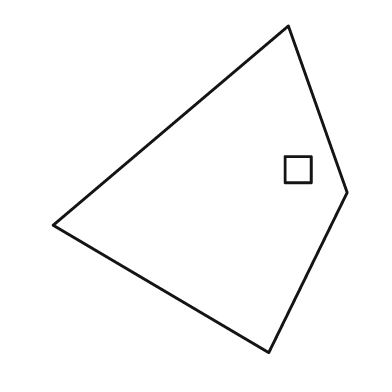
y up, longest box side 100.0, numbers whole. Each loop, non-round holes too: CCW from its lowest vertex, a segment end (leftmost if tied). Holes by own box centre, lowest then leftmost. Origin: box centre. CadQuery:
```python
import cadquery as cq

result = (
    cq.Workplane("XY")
    .moveTo(21.0, -50.0)
    .lineTo(45.0, -1.0)
    .lineTo(27.0, 50.0)
    .lineTo(-45.0, -11.0)
    .close()
    .moveTo(26.0, 2.0)
    .lineTo(34.0, 2.0)
    .lineTo(34.0, 10.0)
    .lineTo(26.0, 10.0)
    .close()
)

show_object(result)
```